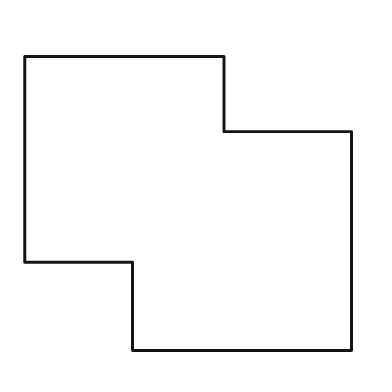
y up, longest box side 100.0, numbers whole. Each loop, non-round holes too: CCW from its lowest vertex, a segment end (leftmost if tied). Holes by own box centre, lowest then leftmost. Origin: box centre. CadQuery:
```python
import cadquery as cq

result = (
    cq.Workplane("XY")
    .moveTo(-17.0, -45.0)
    .lineTo(50.0, -45.0)
    .lineTo(50.0, 22.0)
    .lineTo(11.0, 22.0)
    .lineTo(11.0, 45.0)
    .lineTo(-50.0, 45.0)
    .lineTo(-50.0, -18.0)
    .lineTo(-17.0, -18.0)
    .close()
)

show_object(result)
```